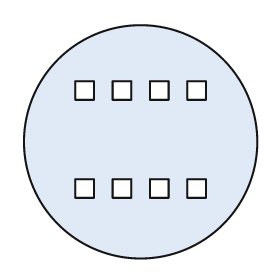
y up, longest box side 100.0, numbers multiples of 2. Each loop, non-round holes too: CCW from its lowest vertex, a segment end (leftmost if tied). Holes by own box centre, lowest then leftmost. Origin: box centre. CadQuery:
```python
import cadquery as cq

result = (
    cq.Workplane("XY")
    .moveTo(0.0, 0.0)
    .circle(50.0)
    .moveTo(-28.0, -24.0)
    .lineTo(-20.0, -24.0)
    .lineTo(-20.0, -16.0)
    .lineTo(-28.0, -16.0)
    .close()
    .moveTo(-12.0, -24.0)
    .lineTo(-4.0, -24.0)
    .lineTo(-4.0, -16.0)
    .lineTo(-12.0, -16.0)
    .close()
    .moveTo(4.0, -24.0)
    .lineTo(12.0, -24.0)
    .lineTo(12.0, -16.0)
    .lineTo(4.0, -16.0)
    .close()
    .moveTo(20.0, -24.0)
    .lineTo(28.0, -24.0)
    .lineTo(28.0, -16.0)
    .lineTo(20.0, -16.0)
    .close()
    .moveTo(-28.0, 18.0)
    .lineTo(-20.0, 18.0)
    .lineTo(-20.0, 26.0)
    .lineTo(-28.0, 26.0)
    .close()
    .moveTo(-12.0, 18.0)
    .lineTo(-4.0, 18.0)
    .lineTo(-4.0, 26.0)
    .lineTo(-12.0, 26.0)
    .close()
    .moveTo(4.0, 18.0)
    .lineTo(12.0, 18.0)
    .lineTo(12.0, 26.0)
    .lineTo(4.0, 26.0)
    .close()
    .moveTo(20.0, 18.0)
    .lineTo(28.0, 18.0)
    .lineTo(28.0, 26.0)
    .lineTo(20.0, 26.0)
    .close()
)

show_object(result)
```